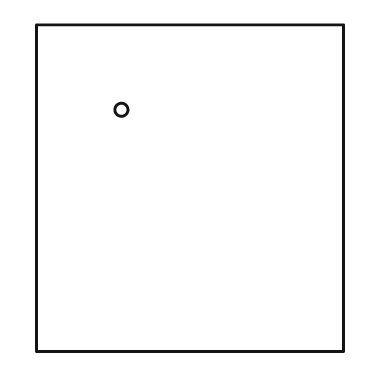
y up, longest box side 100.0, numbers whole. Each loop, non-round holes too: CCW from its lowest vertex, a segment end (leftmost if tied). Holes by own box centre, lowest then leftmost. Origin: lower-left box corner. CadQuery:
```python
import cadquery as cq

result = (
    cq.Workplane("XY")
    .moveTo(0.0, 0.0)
    .lineTo(94.0, 0.0)
    .lineTo(94.0, 100.0)
    .lineTo(0.0, 100.0)
    .close()
    .moveTo(26.0, 74.0)
    .circle(2.0)
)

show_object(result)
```